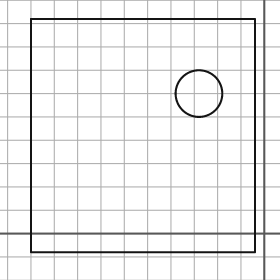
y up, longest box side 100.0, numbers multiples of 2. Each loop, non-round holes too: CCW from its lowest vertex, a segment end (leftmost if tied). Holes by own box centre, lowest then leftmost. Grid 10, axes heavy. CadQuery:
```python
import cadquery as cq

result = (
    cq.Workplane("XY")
    .moveTo(-100.0, -8.0)
    .lineTo(-4.0, -8.0)
    .lineTo(-4.0, 92.0)
    .lineTo(-100.0, 92.0)
    .close()
    .moveTo(-28.0, 60.0)
    .circle(10.0)
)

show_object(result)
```